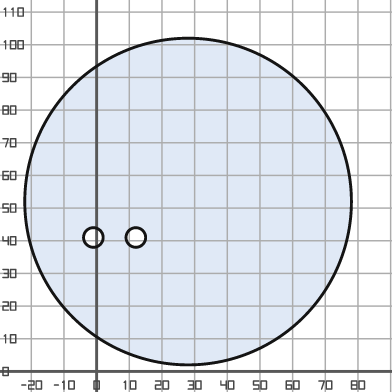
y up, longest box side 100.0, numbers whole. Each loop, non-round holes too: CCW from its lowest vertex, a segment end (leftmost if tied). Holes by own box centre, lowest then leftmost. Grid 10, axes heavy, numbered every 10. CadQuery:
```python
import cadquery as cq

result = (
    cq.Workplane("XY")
    .moveTo(28.0, 52.0)
    .circle(50.0)
    .moveTo(-1.0, 41.0)
    .circle(3.0)
    .moveTo(12.0, 41.0)
    .circle(3.0)
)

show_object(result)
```